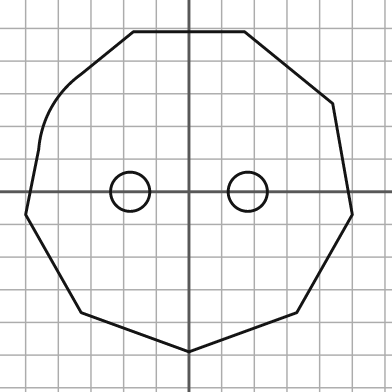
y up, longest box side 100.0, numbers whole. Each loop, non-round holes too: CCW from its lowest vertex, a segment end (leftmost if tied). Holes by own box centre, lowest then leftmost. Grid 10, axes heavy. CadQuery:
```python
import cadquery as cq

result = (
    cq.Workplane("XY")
    .moveTo(0.0, -49.0)
    .lineTo(33.0, -37.0)
    .lineTo(50.0, -7.0)
    .lineTo(44.0, 27.0)
    .lineTo(17.0, 49.0)
    .lineTo(-17.0, 49.0)
    .lineTo(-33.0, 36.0)
    .threePointArc((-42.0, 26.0), (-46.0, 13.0))
    .lineTo(-50.0, -7.0)
    .lineTo(-33.0, -37.0)
    .close()
    .moveTo(-18.0, 0.0)
    .circle(6.0)
    .moveTo(18.0, 0.0)
    .circle(6.0)
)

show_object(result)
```